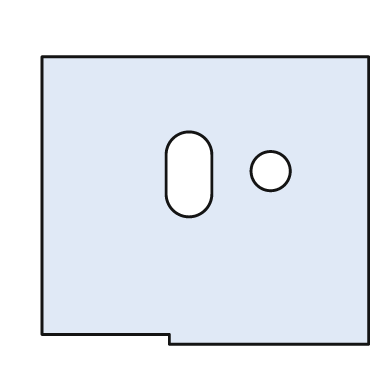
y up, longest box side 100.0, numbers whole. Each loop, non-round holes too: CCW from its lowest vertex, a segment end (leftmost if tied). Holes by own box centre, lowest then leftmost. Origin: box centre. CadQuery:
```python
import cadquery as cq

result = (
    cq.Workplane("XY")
    .moveTo(-11.0, -44.0)
    .lineTo(50.0, -44.0)
    .lineTo(50.0, 44.0)
    .lineTo(-50.0, 44.0)
    .lineTo(-50.0, -41.0)
    .lineTo(-11.0, -41.0)
    .close()
    .moveTo(-12.0, 2.0)
    .threePointArc((-5.0, -5.0), (2.0, 2.0))
    .lineTo(2.0, 14.0)
    .threePointArc((-5.0, 21.0), (-12.0, 14.0))
    .close()
    .moveTo(20.0, 9.0)
    .circle(6.0)
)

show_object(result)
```